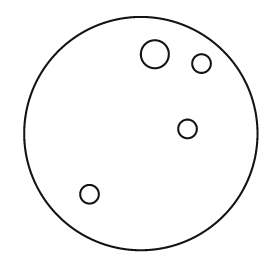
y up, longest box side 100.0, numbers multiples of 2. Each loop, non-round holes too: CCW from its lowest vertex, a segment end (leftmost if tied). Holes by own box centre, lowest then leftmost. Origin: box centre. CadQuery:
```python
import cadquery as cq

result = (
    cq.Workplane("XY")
    .moveTo(0.0, 0.0)
    .circle(50.0)
    .moveTo(-22.0, -26.0)
    .circle(4.0)
    .moveTo(20.0, 2.0)
    .circle(4.0)
    .moveTo(26.0, 30.0)
    .circle(4.0)
    .moveTo(6.0, 34.0)
    .circle(6.0)
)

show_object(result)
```